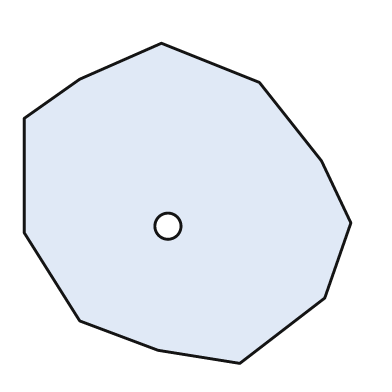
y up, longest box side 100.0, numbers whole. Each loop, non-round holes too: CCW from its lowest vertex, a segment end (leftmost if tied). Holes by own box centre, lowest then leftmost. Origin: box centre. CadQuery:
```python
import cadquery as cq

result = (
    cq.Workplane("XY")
    .moveTo(16.0, -49.0)
    .lineTo(42.0, -29.0)
    .lineTo(50.0, -6.0)
    .lineTo(41.0, 13.0)
    .lineTo(22.0, 37.0)
    .lineTo(-8.0, 49.0)
    .lineTo(-33.0, 38.0)
    .lineTo(-50.0, 26.0)
    .lineTo(-50.0, -9.0)
    .lineTo(-33.0, -36.0)
    .lineTo(-9.0, -45.0)
    .close()
    .moveTo(-6.0, -7.0)
    .circle(4.0)
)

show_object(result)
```